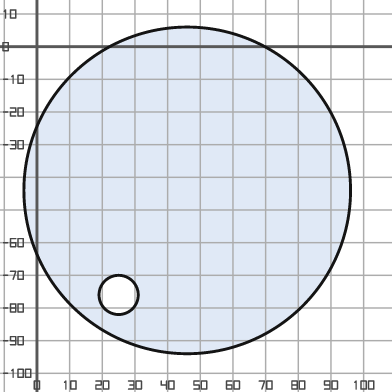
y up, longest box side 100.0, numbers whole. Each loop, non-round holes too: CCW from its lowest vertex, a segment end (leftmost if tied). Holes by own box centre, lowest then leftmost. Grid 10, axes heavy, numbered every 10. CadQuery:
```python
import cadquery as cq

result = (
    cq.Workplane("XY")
    .moveTo(46.0, -44.0)
    .circle(50.0)
    .moveTo(25.0, -76.0)
    .circle(6.0)
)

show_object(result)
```